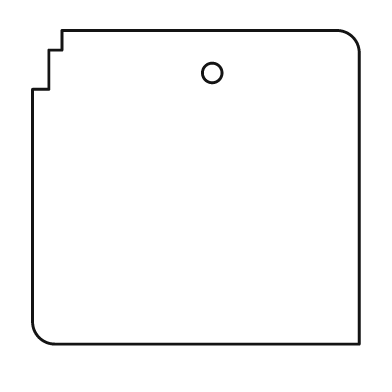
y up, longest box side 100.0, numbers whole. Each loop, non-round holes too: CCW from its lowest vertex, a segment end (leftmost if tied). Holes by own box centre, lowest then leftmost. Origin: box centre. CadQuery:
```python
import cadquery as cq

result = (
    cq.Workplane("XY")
    .moveTo(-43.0, -48.0)
    .lineTo(50.0, -48.0)
    .lineTo(50.0, 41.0)
    .threePointArc((48.0, 46.0), (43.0, 48.0))
    .lineTo(-41.0, 48.0)
    .lineTo(-41.0, 42.0)
    .lineTo(-45.0, 42.0)
    .lineTo(-45.0, 30.0)
    .lineTo(-50.0, 30.0)
    .lineTo(-50.0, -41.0)
    .threePointArc((-48.0, -46.0), (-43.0, -48.0))
    .close()
    .moveTo(5.0, 35.0)
    .circle(3.0)
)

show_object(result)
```